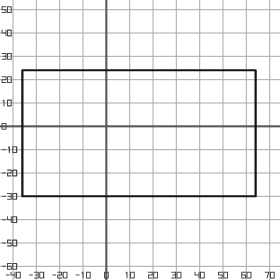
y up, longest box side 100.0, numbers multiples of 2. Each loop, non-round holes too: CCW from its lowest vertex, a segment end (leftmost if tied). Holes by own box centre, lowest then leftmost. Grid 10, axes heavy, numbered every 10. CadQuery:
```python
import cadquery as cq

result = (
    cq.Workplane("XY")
    .moveTo(-36.0, -30.0)
    .lineTo(64.0, -30.0)
    .lineTo(64.0, 24.0)
    .lineTo(-36.0, 24.0)
    .close()
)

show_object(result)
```